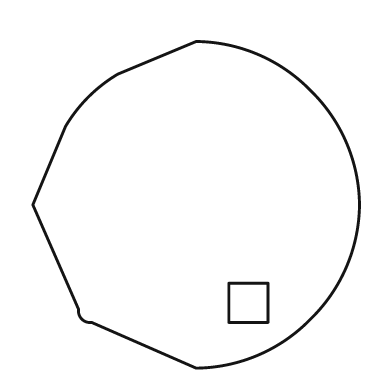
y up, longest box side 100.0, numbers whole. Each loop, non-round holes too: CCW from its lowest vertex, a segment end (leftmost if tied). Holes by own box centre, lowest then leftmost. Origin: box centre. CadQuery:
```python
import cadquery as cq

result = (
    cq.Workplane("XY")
    .moveTo(0.0, -50.0)
    .threePointArc((19.0, -46.0), (35.0, -35.0))
    .threePointArc((46.0, -19.0), (50.0, 0.0))
    .threePointArc((46.0, 19.0), (35.0, 35.0))
    .threePointArc((19.0, 46.0), (0.0, 50.0))
    .lineTo(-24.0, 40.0)
    .threePointArc((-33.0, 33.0), (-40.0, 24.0))
    .lineTo(-50.0, 0.0)
    .lineTo(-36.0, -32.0)
    .threePointArc((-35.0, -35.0), (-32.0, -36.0))
    .close()
    .moveTo(10.0, -36.0)
    .lineTo(22.0, -36.0)
    .lineTo(22.0, -24.0)
    .lineTo(10.0, -24.0)
    .close()
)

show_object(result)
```